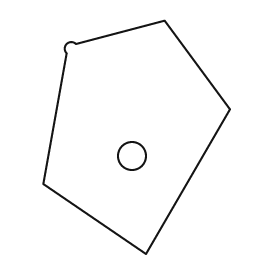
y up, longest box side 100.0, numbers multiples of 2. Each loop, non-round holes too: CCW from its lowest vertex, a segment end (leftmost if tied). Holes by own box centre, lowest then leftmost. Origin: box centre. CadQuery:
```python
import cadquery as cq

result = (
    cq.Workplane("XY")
    .moveTo(4.0, -50.0)
    .lineTo(40.0, 12.0)
    .lineTo(12.0, 50.0)
    .lineTo(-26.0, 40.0)
    .threePointArc((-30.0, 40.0), (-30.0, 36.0))
    .lineTo(-40.0, -20.0)
    .close()
    .moveTo(-2.0, -8.0)
    .circle(6.0)
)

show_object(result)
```